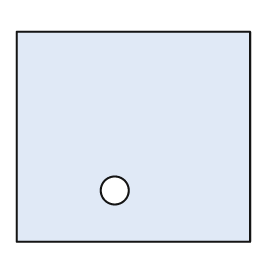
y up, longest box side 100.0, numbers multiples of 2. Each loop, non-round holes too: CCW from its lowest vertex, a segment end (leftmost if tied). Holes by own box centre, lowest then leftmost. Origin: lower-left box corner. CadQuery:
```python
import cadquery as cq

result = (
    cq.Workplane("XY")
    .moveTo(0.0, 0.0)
    .lineTo(100.0, 0.0)
    .lineTo(100.0, 90.0)
    .lineTo(0.0, 90.0)
    .close()
    .moveTo(42.0, 22.0)
    .circle(6.0)
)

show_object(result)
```